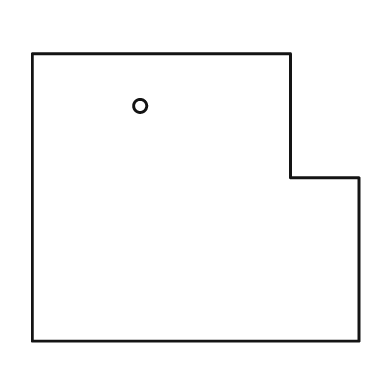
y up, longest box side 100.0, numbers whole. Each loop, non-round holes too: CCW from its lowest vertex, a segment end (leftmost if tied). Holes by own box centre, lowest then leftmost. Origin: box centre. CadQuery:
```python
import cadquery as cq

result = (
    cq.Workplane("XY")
    .moveTo(-50.0, -44.0)
    .lineTo(50.0, -44.0)
    .lineTo(50.0, 6.0)
    .lineTo(29.0, 6.0)
    .lineTo(29.0, 44.0)
    .lineTo(-50.0, 44.0)
    .close()
    .moveTo(-17.0, 28.0)
    .circle(2.0)
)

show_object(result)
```